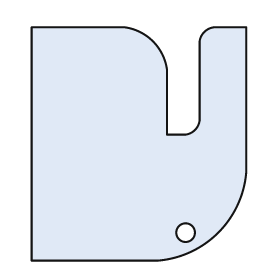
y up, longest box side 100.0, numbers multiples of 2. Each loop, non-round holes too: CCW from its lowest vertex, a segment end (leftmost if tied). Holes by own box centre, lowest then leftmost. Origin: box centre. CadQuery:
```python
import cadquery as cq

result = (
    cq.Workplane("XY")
    .moveTo(-46.0, -50.0)
    .lineTo(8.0, -50.0)
    .threePointArc((34.0, -38.0), (46.0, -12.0))
    .lineTo(46.0, 50.0)
    .lineTo(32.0, 50.0)
    .threePointArc((28.0, 48.0), (26.0, 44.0))
    .lineTo(26.0, 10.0)
    .threePointArc((24.0, 6.0), (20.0, 4.0))
    .lineTo(12.0, 4.0)
    .lineTo(12.0, 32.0)
    .threePointArc((6.0, 44.0), (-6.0, 50.0))
    .lineTo(-46.0, 50.0)
    .close()
    .moveTo(20.0, -38.0)
    .circle(4.0)
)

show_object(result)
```